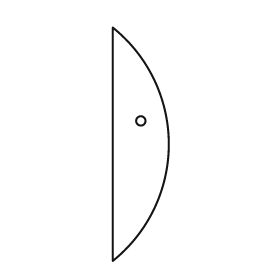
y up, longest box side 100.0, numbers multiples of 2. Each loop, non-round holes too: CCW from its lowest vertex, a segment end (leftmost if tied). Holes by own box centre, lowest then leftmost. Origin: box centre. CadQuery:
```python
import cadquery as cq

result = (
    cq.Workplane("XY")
    .moveTo(-12.0, -50.0)
    .threePointArc((12.0, 0.0), (-12.0, 50.0))
    .close()
    .moveTo(0.0, 10.0)
    .circle(2.0)
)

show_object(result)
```